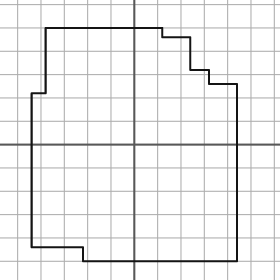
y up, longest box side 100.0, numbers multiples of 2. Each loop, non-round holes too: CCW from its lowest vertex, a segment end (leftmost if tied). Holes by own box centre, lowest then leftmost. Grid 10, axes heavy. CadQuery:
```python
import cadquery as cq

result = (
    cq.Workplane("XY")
    .moveTo(-22.0, -50.0)
    .lineTo(44.0, -50.0)
    .lineTo(44.0, 26.0)
    .lineTo(32.0, 26.0)
    .lineTo(32.0, 32.0)
    .lineTo(24.0, 32.0)
    .lineTo(24.0, 46.0)
    .lineTo(12.0, 46.0)
    .lineTo(12.0, 50.0)
    .lineTo(-38.0, 50.0)
    .lineTo(-38.0, 22.0)
    .lineTo(-44.0, 22.0)
    .lineTo(-44.0, -44.0)
    .lineTo(-22.0, -44.0)
    .close()
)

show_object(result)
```